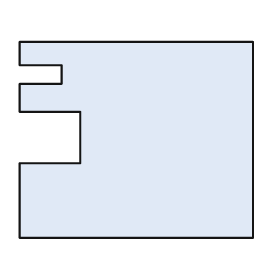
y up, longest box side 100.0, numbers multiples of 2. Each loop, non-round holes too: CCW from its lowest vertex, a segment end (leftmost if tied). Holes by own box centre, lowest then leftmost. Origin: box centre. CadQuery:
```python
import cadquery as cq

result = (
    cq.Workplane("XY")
    .moveTo(-50.0, -42.0)
    .lineTo(50.0, -42.0)
    .lineTo(50.0, 42.0)
    .lineTo(-50.0, 42.0)
    .lineTo(-50.0, 32.0)
    .lineTo(-32.0, 32.0)
    .lineTo(-32.0, 24.0)
    .lineTo(-50.0, 24.0)
    .lineTo(-50.0, 12.0)
    .lineTo(-24.0, 12.0)
    .lineTo(-24.0, -10.0)
    .lineTo(-50.0, -10.0)
    .close()
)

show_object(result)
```